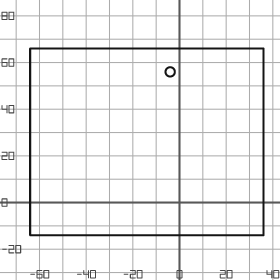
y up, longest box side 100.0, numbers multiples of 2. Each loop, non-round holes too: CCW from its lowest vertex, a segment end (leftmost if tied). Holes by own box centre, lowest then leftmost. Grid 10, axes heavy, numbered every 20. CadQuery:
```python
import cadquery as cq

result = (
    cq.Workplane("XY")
    .moveTo(-64.0, -14.0)
    .lineTo(36.0, -14.0)
    .lineTo(36.0, 66.0)
    .lineTo(-64.0, 66.0)
    .close()
    .moveTo(-4.0, 56.0)
    .circle(2.0)
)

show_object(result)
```